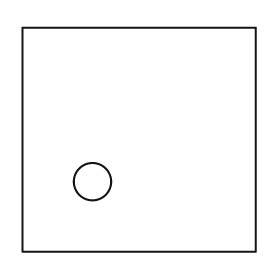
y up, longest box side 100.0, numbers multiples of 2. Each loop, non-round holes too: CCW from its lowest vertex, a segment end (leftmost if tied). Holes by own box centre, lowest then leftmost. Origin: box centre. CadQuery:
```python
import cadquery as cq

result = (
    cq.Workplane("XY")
    .moveTo(-50.0, -48.0)
    .lineTo(50.0, -48.0)
    .lineTo(50.0, 48.0)
    .lineTo(-50.0, 48.0)
    .close()
    .moveTo(-20.0, -18.0)
    .circle(8.0)
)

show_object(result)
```